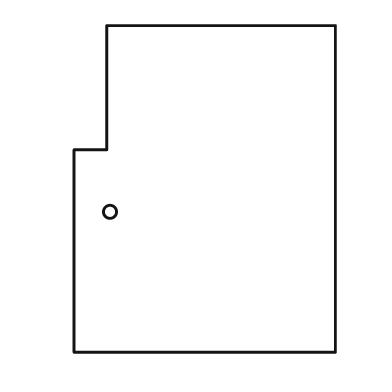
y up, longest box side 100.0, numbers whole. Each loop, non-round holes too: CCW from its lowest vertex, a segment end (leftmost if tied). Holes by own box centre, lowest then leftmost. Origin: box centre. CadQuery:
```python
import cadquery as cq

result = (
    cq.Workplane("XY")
    .moveTo(-40.0, -50.0)
    .lineTo(40.0, -50.0)
    .lineTo(40.0, 50.0)
    .lineTo(-30.0, 50.0)
    .lineTo(-30.0, 12.0)
    .lineTo(-40.0, 12.0)
    .close()
    .moveTo(-29.0, -7.0)
    .circle(2.0)
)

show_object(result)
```